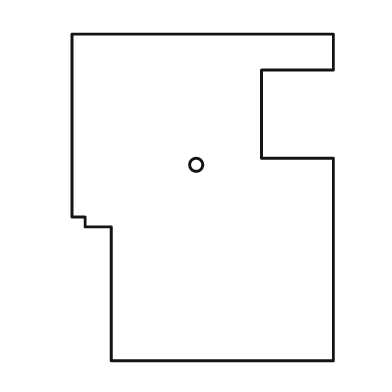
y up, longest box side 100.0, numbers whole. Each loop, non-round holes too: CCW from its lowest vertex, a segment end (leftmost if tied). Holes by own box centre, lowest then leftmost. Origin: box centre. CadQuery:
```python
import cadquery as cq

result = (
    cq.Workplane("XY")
    .moveTo(-28.0, -50.0)
    .lineTo(40.0, -50.0)
    .lineTo(40.0, 12.0)
    .lineTo(18.0, 12.0)
    .lineTo(18.0, 39.0)
    .lineTo(40.0, 39.0)
    .lineTo(40.0, 50.0)
    .lineTo(-40.0, 50.0)
    .lineTo(-40.0, -6.0)
    .lineTo(-36.0, -6.0)
    .lineTo(-36.0, -9.0)
    .lineTo(-28.0, -9.0)
    .close()
    .moveTo(-2.0, 10.0)
    .circle(2.0)
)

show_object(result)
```